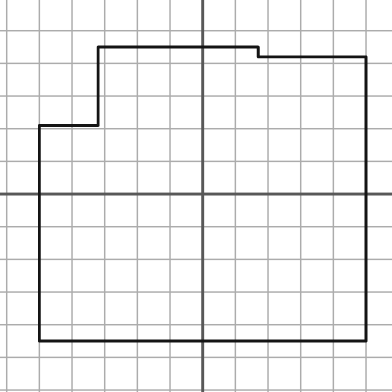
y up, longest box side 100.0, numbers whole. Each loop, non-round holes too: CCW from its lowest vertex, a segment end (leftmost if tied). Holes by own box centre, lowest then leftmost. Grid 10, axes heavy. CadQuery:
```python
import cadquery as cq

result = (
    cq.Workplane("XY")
    .moveTo(-50.0, -45.0)
    .lineTo(50.0, -45.0)
    .lineTo(50.0, 42.0)
    .lineTo(17.0, 42.0)
    .lineTo(17.0, 45.0)
    .lineTo(-32.0, 45.0)
    .lineTo(-32.0, 21.0)
    .lineTo(-50.0, 21.0)
    .close()
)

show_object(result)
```